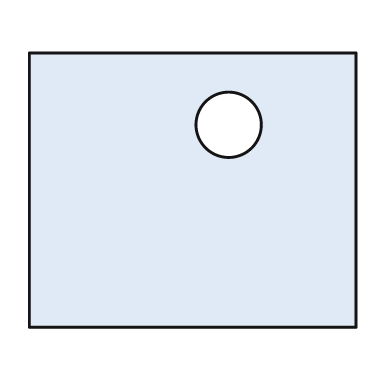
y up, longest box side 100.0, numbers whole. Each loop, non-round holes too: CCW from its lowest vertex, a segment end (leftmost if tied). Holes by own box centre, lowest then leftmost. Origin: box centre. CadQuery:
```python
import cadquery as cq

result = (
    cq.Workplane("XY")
    .moveTo(-50.0, -42.0)
    .lineTo(50.0, -42.0)
    .lineTo(50.0, 42.0)
    .lineTo(-50.0, 42.0)
    .close()
    .moveTo(11.0, 20.0)
    .circle(10.0)
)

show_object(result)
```